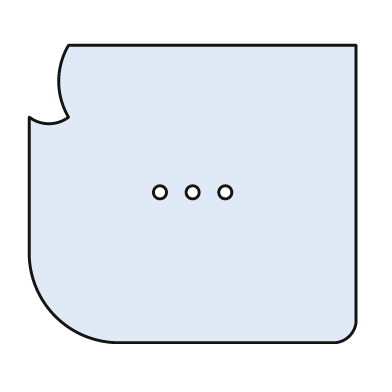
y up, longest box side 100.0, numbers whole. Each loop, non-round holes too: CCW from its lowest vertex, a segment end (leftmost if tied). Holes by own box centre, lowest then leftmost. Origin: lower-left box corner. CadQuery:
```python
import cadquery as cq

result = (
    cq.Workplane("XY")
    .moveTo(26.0, 0.0)
    .lineTo(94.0, 0.0)
    .threePointArc((98.0, 2.0), (100.0, 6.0))
    .lineTo(100.0, 91.0)
    .lineTo(12.0, 91.0)
    .threePointArc((9.0, 80.0), (12.0, 69.0))
    .threePointArc((6.0, 67.0), (0.0, 69.0))
    .lineTo(0.0, 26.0)
    .threePointArc((8.0, 8.0), (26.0, 0.0))
    .close()
    .moveTo(40.0, 46.0)
    .circle(2.0)
    .moveTo(50.0, 46.0)
    .circle(2.0)
    .moveTo(60.0, 46.0)
    .circle(2.0)
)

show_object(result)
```